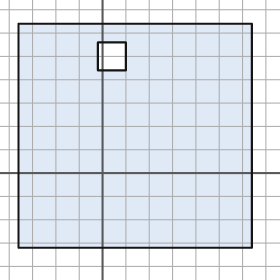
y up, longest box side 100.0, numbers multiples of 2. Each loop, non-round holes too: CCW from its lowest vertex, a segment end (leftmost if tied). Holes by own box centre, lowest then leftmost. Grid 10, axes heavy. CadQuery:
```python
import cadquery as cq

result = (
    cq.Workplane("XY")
    .moveTo(-36.0, -32.0)
    .lineTo(64.0, -32.0)
    .lineTo(64.0, 64.0)
    .lineTo(-36.0, 64.0)
    .close()
    .moveTo(-2.0, 44.0)
    .lineTo(10.0, 44.0)
    .lineTo(10.0, 56.0)
    .lineTo(-2.0, 56.0)
    .close()
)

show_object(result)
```